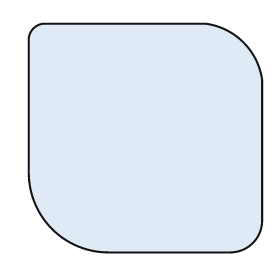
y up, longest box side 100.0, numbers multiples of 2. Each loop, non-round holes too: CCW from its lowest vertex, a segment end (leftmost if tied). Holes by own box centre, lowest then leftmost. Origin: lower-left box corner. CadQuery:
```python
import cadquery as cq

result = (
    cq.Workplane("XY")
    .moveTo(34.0, 0.0)
    .lineTo(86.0, 0.0)
    .threePointArc((96.0, 4.0), (100.0, 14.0))
    .lineTo(100.0, 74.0)
    .threePointArc((92.0, 90.0), (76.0, 98.0))
    .lineTo(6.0, 98.0)
    .threePointArc((2.0, 96.0), (0.0, 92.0))
    .lineTo(0.0, 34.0)
    .threePointArc((10.0, 10.0), (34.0, 0.0))
    .close()
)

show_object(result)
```